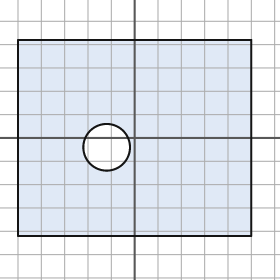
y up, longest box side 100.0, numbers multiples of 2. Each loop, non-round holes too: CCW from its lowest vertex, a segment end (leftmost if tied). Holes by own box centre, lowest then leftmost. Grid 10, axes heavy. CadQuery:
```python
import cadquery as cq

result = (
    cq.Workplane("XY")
    .moveTo(-50.0, -42.0)
    .lineTo(50.0, -42.0)
    .lineTo(50.0, 42.0)
    .lineTo(-50.0, 42.0)
    .close()
    .moveTo(-12.0, -4.0)
    .circle(10.0)
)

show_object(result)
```